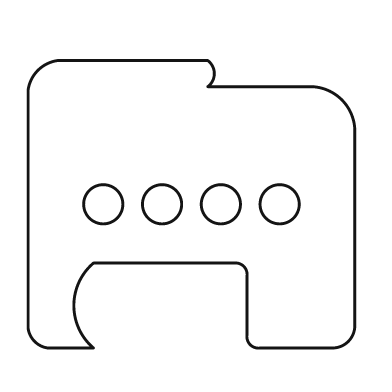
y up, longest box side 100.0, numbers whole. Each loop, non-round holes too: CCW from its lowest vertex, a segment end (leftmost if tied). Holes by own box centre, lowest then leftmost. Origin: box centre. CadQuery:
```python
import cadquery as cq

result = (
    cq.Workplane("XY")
    .moveTo(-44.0, -44.0)
    .lineTo(-30.0, -44.0)
    .threePointArc((-36.0, -31.0), (-30.0, -18.0))
    .lineTo(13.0, -18.0)
    .threePointArc((16.0, -19.0), (17.0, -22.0))
    .lineTo(17.0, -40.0)
    .threePointArc((18.0, -43.0), (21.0, -44.0))
    .lineTo(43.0, -44.0)
    .threePointArc((48.0, -42.0), (50.0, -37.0))
    .lineTo(50.0, 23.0)
    .threePointArc((46.0, 32.0), (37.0, 36.0))
    .lineTo(5.0, 36.0)
    .threePointArc((7.0, 40.0), (5.0, 44.0))
    .lineTo(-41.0, 44.0)
    .threePointArc((-47.0, 41.0), (-50.0, 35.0))
    .lineTo(-50.0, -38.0)
    .threePointArc((-48.0, -42.0), (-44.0, -44.0))
    .close()
    .moveTo(-27.0, 0.0)
    .circle(6.0)
    .moveTo(-9.0, 0.0)
    .circle(6.0)
    .moveTo(9.0, 0.0)
    .circle(6.0)
    .moveTo(27.0, 0.0)
    .circle(6.0)
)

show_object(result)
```